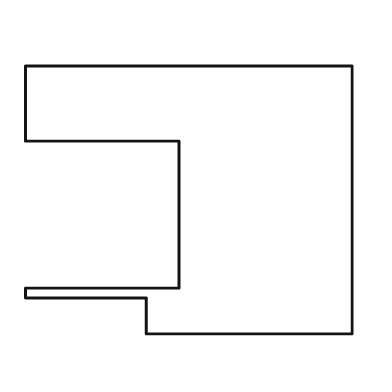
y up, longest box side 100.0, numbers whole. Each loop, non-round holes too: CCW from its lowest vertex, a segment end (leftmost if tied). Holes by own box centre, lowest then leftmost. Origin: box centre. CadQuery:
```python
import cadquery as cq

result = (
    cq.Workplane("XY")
    .moveTo(-13.0, -41.0)
    .lineTo(50.0, -41.0)
    .lineTo(50.0, 41.0)
    .lineTo(-50.0, 41.0)
    .lineTo(-50.0, 18.0)
    .lineTo(-3.0, 18.0)
    .lineTo(-3.0, -27.0)
    .lineTo(-50.0, -27.0)
    .lineTo(-50.0, -30.0)
    .lineTo(-13.0, -30.0)
    .close()
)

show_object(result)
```